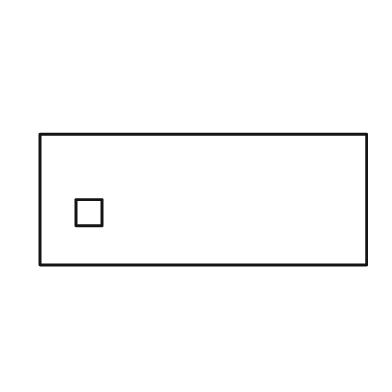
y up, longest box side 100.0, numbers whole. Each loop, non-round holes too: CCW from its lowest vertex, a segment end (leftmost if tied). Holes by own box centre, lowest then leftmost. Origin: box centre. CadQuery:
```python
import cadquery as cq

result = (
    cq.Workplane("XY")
    .moveTo(-50.0, -20.0)
    .lineTo(50.0, -20.0)
    .lineTo(50.0, 20.0)
    .lineTo(-50.0, 20.0)
    .close()
    .moveTo(-39.0, -8.0)
    .lineTo(-31.0, -8.0)
    .lineTo(-31.0, 0.0)
    .lineTo(-39.0, 0.0)
    .close()
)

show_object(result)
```